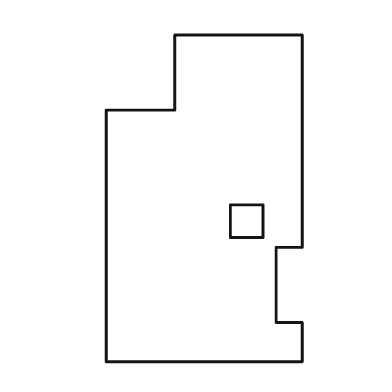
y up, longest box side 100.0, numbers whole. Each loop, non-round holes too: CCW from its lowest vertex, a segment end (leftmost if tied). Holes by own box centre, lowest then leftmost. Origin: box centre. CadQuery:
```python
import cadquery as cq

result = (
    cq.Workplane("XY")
    .moveTo(-30.0, -50.0)
    .lineTo(30.0, -50.0)
    .lineTo(30.0, -38.0)
    .lineTo(22.0, -38.0)
    .lineTo(22.0, -15.0)
    .lineTo(30.0, -15.0)
    .lineTo(30.0, 50.0)
    .lineTo(-9.0, 50.0)
    .lineTo(-9.0, 27.0)
    .lineTo(-30.0, 27.0)
    .close()
    .moveTo(8.0, -12.0)
    .lineTo(18.0, -12.0)
    .lineTo(18.0, -2.0)
    .lineTo(8.0, -2.0)
    .close()
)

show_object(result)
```